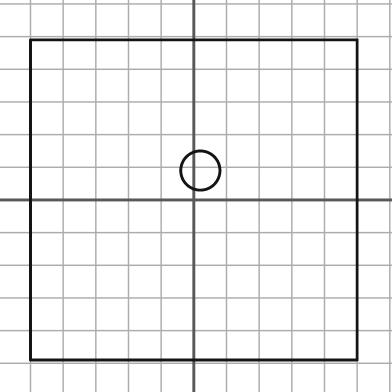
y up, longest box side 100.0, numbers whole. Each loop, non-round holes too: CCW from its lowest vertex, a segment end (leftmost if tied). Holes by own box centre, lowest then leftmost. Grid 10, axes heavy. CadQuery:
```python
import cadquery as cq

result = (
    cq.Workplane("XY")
    .moveTo(-50.0, -49.0)
    .lineTo(50.0, -49.0)
    .lineTo(50.0, 49.0)
    .lineTo(-50.0, 49.0)
    .close()
    .moveTo(2.0, 9.0)
    .circle(6.0)
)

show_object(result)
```